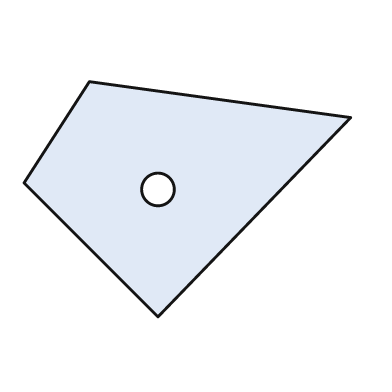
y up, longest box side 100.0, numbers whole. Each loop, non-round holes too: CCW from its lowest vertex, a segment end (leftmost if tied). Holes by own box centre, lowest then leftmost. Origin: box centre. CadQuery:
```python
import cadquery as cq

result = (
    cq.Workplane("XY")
    .moveTo(-9.0, -36.0)
    .lineTo(50.0, 25.0)
    .lineTo(-30.0, 36.0)
    .lineTo(-50.0, 5.0)
    .close()
    .moveTo(-9.0, 3.0)
    .circle(5.0)
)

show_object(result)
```